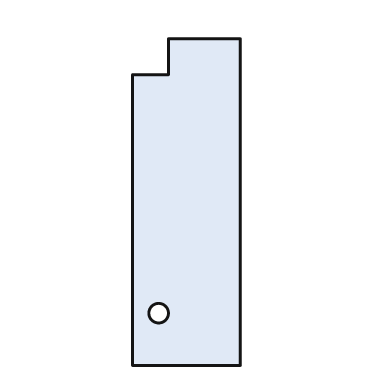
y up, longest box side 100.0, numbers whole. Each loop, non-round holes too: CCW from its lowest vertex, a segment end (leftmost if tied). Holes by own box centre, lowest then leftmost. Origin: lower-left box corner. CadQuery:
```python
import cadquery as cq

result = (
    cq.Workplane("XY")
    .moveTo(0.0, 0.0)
    .lineTo(33.0, 0.0)
    .lineTo(33.0, 100.0)
    .lineTo(11.0, 100.0)
    .lineTo(11.0, 89.0)
    .lineTo(0.0, 89.0)
    .close()
    .moveTo(8.0, 16.0)
    .circle(3.0)
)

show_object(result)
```